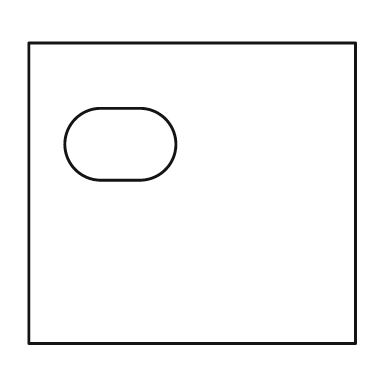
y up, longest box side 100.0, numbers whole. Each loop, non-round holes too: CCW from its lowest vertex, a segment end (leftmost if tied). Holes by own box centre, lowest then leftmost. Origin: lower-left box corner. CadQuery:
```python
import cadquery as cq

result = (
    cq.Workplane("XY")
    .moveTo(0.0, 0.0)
    .lineTo(100.0, 0.0)
    .lineTo(100.0, 92.0)
    .lineTo(0.0, 92.0)
    .close()
    .moveTo(22.0, 50.0)
    .lineTo(34.0, 50.0)
    .threePointArc((45.0, 61.0), (34.0, 72.0))
    .lineTo(22.0, 72.0)
    .threePointArc((11.0, 61.0), (22.0, 50.0))
    .close()
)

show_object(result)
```